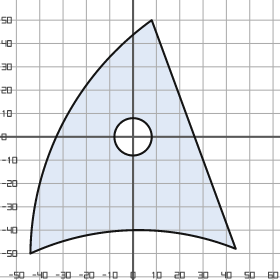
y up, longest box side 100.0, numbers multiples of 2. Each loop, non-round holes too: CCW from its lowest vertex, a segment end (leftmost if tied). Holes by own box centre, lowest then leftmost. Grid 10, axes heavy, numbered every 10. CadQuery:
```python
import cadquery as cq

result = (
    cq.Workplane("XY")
    .moveTo(-44.0, -50.0)
    .threePointArc((0.0, -40.0), (44.0, -48.0))
    .lineTo(8.0, 50.0)
    .threePointArc((-30.0, 6.0), (-44.0, -50.0))
    .close()
    .moveTo(0.0, 0.0)
    .circle(8.0)
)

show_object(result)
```